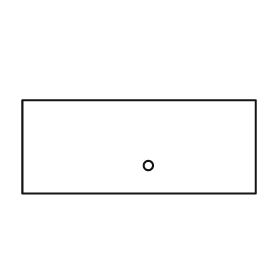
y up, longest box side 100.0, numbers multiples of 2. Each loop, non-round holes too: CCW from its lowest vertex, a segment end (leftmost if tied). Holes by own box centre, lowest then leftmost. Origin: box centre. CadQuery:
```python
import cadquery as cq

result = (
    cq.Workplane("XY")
    .moveTo(-50.0, -20.0)
    .lineTo(50.0, -20.0)
    .lineTo(50.0, 20.0)
    .lineTo(-50.0, 20.0)
    .close()
    .moveTo(4.0, -8.0)
    .circle(2.0)
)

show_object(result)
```